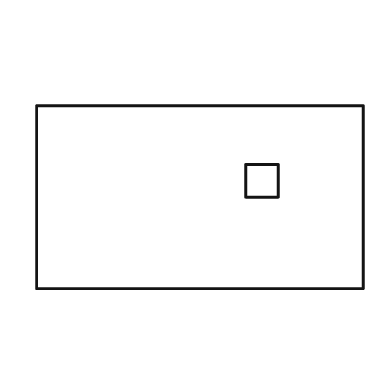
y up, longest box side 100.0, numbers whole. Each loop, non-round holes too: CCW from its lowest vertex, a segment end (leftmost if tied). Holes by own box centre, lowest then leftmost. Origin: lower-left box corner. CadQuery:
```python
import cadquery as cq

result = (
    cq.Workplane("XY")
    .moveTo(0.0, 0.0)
    .lineTo(100.0, 0.0)
    .lineTo(100.0, 56.0)
    .lineTo(0.0, 56.0)
    .close()
    .moveTo(64.0, 28.0)
    .lineTo(74.0, 28.0)
    .lineTo(74.0, 38.0)
    .lineTo(64.0, 38.0)
    .close()
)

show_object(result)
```